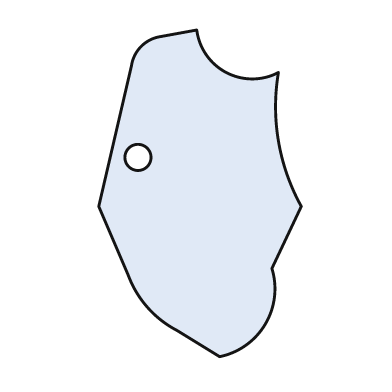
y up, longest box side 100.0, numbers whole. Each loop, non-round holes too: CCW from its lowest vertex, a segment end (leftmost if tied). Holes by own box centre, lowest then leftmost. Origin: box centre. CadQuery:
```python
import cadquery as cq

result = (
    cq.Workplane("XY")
    .moveTo(6.0, -50.0)
    .threePointArc((20.0, -40.0), (22.0, -23.0))
    .lineTo(31.0, -4.0)
    .threePointArc((24.0, 16.0), (24.0, 37.0))
    .threePointArc((8.0, 37.0), (-1.0, 50.0))
    .lineTo(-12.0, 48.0)
    .threePointArc((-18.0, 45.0), (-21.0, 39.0))
    .lineTo(-31.0, -4.0)
    .lineTo(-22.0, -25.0)
    .threePointArc((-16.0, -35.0), (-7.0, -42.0))
    .close()
    .moveTo(-19.0, 11.0)
    .circle(4.0)
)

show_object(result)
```